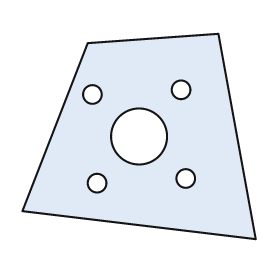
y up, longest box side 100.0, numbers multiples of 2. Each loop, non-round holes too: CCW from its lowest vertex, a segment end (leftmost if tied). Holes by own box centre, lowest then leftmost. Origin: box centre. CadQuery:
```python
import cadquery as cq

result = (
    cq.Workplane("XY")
    .moveTo(50.0, -44.0)
    .lineTo(34.0, 44.0)
    .lineTo(-22.0, 40.0)
    .lineTo(-50.0, -32.0)
    .close()
    .moveTo(-18.0, -20.0)
    .circle(4.0)
    .moveTo(20.0, -18.0)
    .circle(4.0)
    .moveTo(0.0, 0.0)
    .circle(12.0)
    .moveTo(-20.0, 18.0)
    .circle(4.0)
    .moveTo(18.0, 20.0)
    .circle(4.0)
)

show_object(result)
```